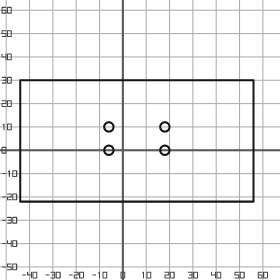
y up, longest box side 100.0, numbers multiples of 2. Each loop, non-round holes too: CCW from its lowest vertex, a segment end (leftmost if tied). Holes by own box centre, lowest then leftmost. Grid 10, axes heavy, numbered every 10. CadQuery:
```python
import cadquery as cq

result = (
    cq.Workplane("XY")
    .moveTo(-44.0, -22.0)
    .lineTo(56.0, -22.0)
    .lineTo(56.0, 30.0)
    .lineTo(-44.0, 30.0)
    .close()
    .moveTo(-6.0, 0.0)
    .circle(2.0)
    .moveTo(18.0, 0.0)
    .circle(2.0)
    .moveTo(-6.0, 10.0)
    .circle(2.0)
    .moveTo(18.0, 10.0)
    .circle(2.0)
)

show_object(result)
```